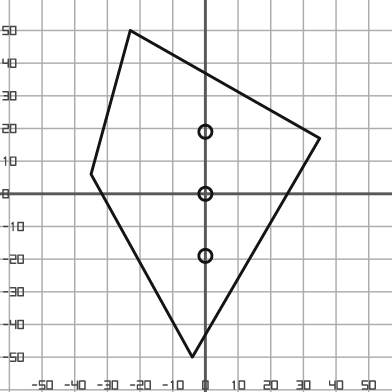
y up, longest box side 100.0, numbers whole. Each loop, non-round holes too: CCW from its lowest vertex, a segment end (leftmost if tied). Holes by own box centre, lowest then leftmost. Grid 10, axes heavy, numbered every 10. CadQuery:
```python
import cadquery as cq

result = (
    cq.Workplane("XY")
    .moveTo(-4.0, -50.0)
    .lineTo(35.0, 17.0)
    .lineTo(-23.0, 50.0)
    .lineTo(-35.0, 6.0)
    .close()
    .moveTo(0.0, -19.0)
    .circle(2.0)
    .moveTo(0.0, 0.0)
    .circle(2.0)
    .moveTo(0.0, 19.0)
    .circle(2.0)
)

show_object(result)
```